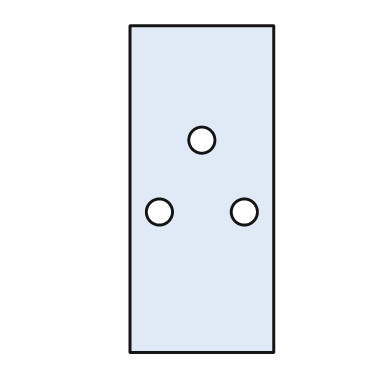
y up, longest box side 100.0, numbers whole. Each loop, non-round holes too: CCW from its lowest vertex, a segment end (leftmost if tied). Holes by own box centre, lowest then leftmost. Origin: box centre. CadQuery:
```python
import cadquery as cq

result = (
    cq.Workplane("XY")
    .moveTo(-22.0, -50.0)
    .lineTo(22.0, -50.0)
    .lineTo(22.0, 50.0)
    .lineTo(-22.0, 50.0)
    .close()
    .moveTo(-13.0, -7.0)
    .circle(4.0)
    .moveTo(13.0, -7.0)
    .circle(4.0)
    .moveTo(0.0, 15.0)
    .circle(4.0)
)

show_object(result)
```